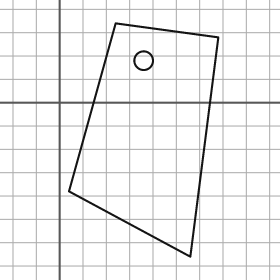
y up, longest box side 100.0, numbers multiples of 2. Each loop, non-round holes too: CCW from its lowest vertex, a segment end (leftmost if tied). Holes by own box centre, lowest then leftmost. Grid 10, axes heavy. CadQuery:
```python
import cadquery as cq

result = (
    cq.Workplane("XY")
    .moveTo(56.0, -66.0)
    .lineTo(68.0, 28.0)
    .lineTo(24.0, 34.0)
    .lineTo(4.0, -38.0)
    .close()
    .moveTo(36.0, 18.0)
    .circle(4.0)
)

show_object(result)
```